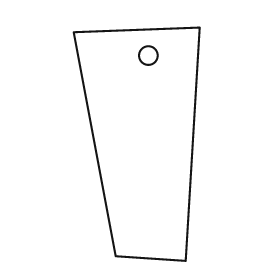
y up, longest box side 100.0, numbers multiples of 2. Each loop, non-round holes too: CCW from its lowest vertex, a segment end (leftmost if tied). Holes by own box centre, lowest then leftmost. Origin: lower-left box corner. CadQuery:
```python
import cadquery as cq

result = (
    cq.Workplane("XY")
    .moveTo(48.0, 0.0)
    .lineTo(54.0, 100.0)
    .lineTo(0.0, 98.0)
    .lineTo(18.0, 2.0)
    .close()
    .moveTo(32.0, 88.0)
    .circle(4.0)
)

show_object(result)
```